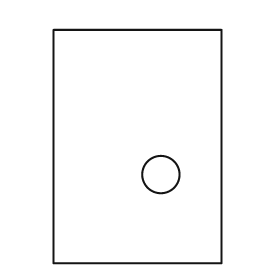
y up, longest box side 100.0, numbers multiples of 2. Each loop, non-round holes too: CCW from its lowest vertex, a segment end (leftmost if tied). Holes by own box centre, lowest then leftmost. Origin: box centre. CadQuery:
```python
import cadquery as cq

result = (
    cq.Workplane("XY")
    .moveTo(-36.0, -50.0)
    .lineTo(36.0, -50.0)
    .lineTo(36.0, 50.0)
    .lineTo(-36.0, 50.0)
    .close()
    .moveTo(10.0, -12.0)
    .circle(8.0)
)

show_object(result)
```